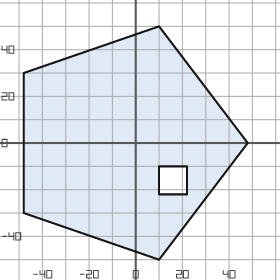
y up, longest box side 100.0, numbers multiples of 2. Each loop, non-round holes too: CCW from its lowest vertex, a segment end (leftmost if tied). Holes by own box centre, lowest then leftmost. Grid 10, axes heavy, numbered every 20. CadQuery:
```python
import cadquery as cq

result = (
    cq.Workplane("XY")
    .moveTo(10.0, -50.0)
    .lineTo(48.0, 0.0)
    .lineTo(10.0, 50.0)
    .lineTo(-48.0, 30.0)
    .lineTo(-48.0, -30.0)
    .close()
    .moveTo(10.0, -22.0)
    .lineTo(22.0, -22.0)
    .lineTo(22.0, -10.0)
    .lineTo(10.0, -10.0)
    .close()
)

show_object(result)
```